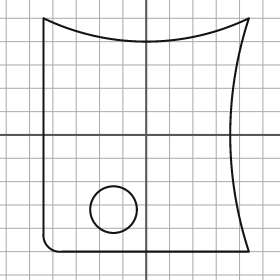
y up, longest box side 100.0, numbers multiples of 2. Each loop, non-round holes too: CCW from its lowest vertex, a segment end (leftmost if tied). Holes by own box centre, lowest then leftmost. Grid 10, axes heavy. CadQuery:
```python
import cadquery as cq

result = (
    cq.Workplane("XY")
    .moveTo(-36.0, -50.0)
    .lineTo(44.0, -50.0)
    .threePointArc((36.0, 0.0), (44.0, 50.0))
    .threePointArc((0.0, 40.0), (-44.0, 50.0))
    .lineTo(-44.0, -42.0)
    .threePointArc((-42.0, -48.0), (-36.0, -50.0))
    .close()
    .moveTo(-14.0, -32.0)
    .circle(10.0)
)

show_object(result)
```